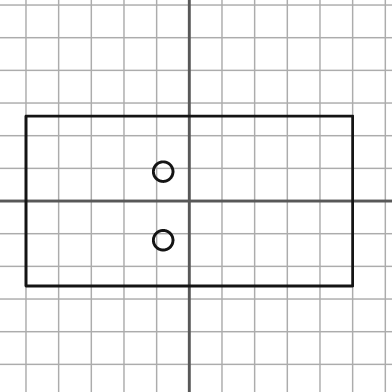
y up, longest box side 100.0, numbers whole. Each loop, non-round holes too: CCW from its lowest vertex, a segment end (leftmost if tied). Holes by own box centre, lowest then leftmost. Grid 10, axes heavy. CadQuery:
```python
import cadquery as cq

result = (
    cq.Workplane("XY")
    .moveTo(-50.0, -26.0)
    .lineTo(50.0, -26.0)
    .lineTo(50.0, 26.0)
    .lineTo(-50.0, 26.0)
    .close()
    .moveTo(-8.0, -12.0)
    .circle(3.0)
    .moveTo(-8.0, 9.0)
    .circle(3.0)
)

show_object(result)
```